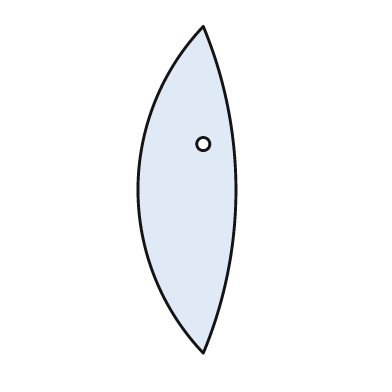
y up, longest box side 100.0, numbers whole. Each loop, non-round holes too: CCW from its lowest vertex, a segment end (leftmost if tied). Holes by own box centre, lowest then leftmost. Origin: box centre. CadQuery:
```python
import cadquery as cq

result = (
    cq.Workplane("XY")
    .moveTo(5.0, -50.0)
    .threePointArc((15.0, 0.0), (5.0, 50.0))
    .threePointArc((-15.0, 0.0), (5.0, -50.0))
    .close()
    .moveTo(5.0, 14.0)
    .circle(2.0)
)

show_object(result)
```